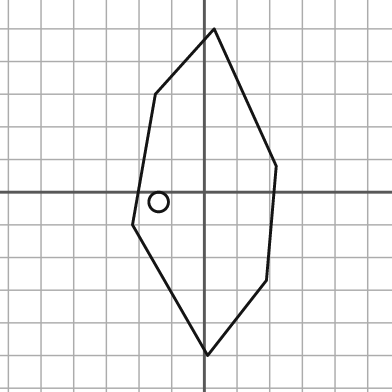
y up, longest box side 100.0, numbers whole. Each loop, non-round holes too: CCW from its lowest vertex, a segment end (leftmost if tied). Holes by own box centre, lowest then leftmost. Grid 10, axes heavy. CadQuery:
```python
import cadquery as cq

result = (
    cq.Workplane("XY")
    .moveTo(1.0, -50.0)
    .lineTo(19.0, -27.0)
    .lineTo(22.0, 8.0)
    .lineTo(3.0, 50.0)
    .lineTo(-15.0, 30.0)
    .lineTo(-22.0, -10.0)
    .close()
    .moveTo(-14.0, -3.0)
    .circle(3.0)
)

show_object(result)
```